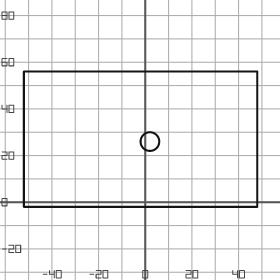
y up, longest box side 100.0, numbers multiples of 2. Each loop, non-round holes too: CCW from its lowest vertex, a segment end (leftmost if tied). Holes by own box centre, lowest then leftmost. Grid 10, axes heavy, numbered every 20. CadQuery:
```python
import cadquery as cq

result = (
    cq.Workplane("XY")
    .moveTo(-52.0, -2.0)
    .lineTo(48.0, -2.0)
    .lineTo(48.0, 56.0)
    .lineTo(-52.0, 56.0)
    .close()
    .moveTo(2.0, 26.0)
    .circle(4.0)
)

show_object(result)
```